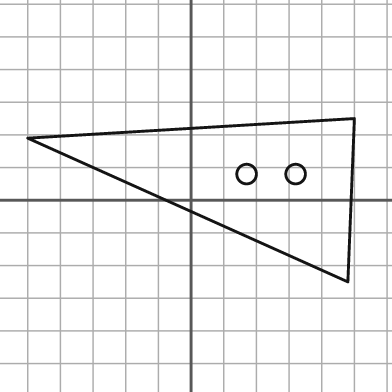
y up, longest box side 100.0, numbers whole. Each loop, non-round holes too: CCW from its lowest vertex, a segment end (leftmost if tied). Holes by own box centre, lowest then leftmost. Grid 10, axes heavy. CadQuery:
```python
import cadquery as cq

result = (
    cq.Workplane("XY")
    .moveTo(48.0, -25.0)
    .lineTo(50.0, 25.0)
    .lineTo(-50.0, 19.0)
    .close()
    .moveTo(17.0, 8.0)
    .circle(3.0)
    .moveTo(32.0, 8.0)
    .circle(3.0)
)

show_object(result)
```